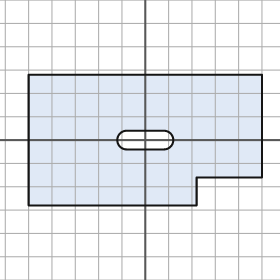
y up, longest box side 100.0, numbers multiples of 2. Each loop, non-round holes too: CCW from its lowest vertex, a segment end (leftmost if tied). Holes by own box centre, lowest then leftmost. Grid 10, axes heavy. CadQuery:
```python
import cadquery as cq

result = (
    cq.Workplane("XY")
    .moveTo(-50.0, -28.0)
    .lineTo(22.0, -28.0)
    .lineTo(22.0, -16.0)
    .lineTo(50.0, -16.0)
    .lineTo(50.0, 28.0)
    .lineTo(-50.0, 28.0)
    .close()
    .moveTo(-8.0, -4.0)
    .lineTo(8.0, -4.0)
    .threePointArc((12.0, 0.0), (8.0, 4.0))
    .lineTo(-8.0, 4.0)
    .threePointArc((-12.0, 0.0), (-8.0, -4.0))
    .close()
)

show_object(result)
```